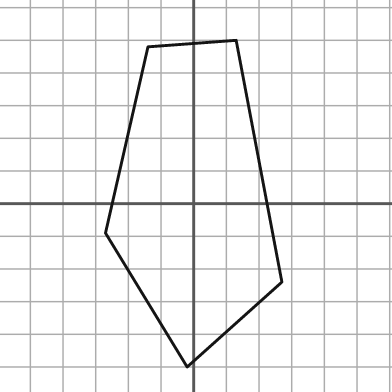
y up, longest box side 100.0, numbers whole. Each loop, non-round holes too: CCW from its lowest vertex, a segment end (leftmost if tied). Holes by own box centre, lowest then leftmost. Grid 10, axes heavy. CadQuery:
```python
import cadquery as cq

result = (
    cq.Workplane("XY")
    .moveTo(-2.0, -50.0)
    .lineTo(27.0, -24.0)
    .lineTo(13.0, 50.0)
    .lineTo(-14.0, 48.0)
    .lineTo(-27.0, -9.0)
    .close()
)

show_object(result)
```